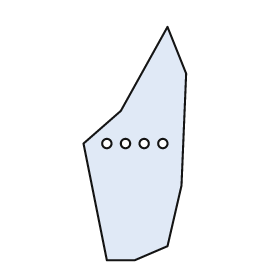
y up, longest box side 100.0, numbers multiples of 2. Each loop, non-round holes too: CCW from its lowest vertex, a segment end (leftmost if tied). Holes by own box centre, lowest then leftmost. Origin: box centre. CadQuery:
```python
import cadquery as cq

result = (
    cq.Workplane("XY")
    .moveTo(-12.0, -50.0)
    .lineTo(0.0, -50.0)
    .lineTo(14.0, -44.0)
    .lineTo(20.0, -18.0)
    .lineTo(22.0, 30.0)
    .lineTo(14.0, 50.0)
    .lineTo(-6.0, 14.0)
    .lineTo(-22.0, 0.0)
    .close()
    .moveTo(-12.0, 0.0)
    .circle(2.0)
    .moveTo(-4.0, 0.0)
    .circle(2.0)
    .moveTo(4.0, 0.0)
    .circle(2.0)
    .moveTo(12.0, 0.0)
    .circle(2.0)
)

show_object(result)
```